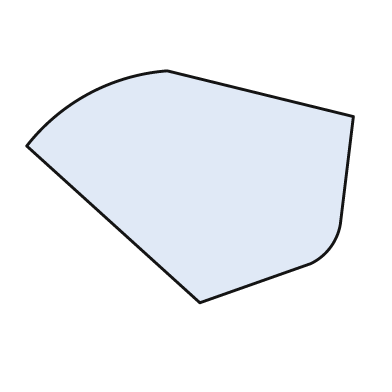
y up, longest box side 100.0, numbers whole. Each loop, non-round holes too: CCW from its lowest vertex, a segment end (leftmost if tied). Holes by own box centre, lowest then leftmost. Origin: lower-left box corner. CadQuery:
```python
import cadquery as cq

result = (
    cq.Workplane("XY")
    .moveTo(53.0, 0.0)
    .lineTo(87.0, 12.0)
    .threePointArc((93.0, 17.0), (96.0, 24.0))
    .lineTo(100.0, 57.0)
    .lineTo(43.0, 71.0)
    .threePointArc((19.0, 64.0), (0.0, 48.0))
    .close()
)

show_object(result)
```